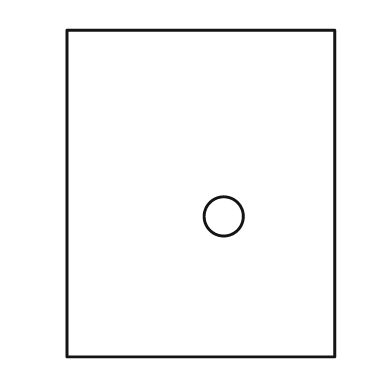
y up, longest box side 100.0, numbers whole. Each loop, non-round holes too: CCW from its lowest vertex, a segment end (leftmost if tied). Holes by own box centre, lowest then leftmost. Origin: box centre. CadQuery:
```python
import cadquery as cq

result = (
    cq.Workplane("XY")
    .moveTo(-41.0, -50.0)
    .lineTo(41.0, -50.0)
    .lineTo(41.0, 50.0)
    .lineTo(-41.0, 50.0)
    .close()
    .moveTo(7.0, -7.0)
    .circle(6.0)
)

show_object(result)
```